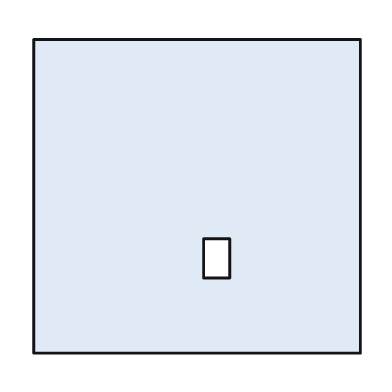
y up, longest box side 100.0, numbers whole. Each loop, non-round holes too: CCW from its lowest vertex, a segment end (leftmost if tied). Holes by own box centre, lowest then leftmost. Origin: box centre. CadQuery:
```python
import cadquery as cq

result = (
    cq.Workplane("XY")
    .moveTo(-50.0, -48.0)
    .lineTo(50.0, -48.0)
    .lineTo(50.0, 48.0)
    .lineTo(-50.0, 48.0)
    .close()
    .moveTo(2.0, -25.0)
    .lineTo(10.0, -25.0)
    .lineTo(10.0, -13.0)
    .lineTo(2.0, -13.0)
    .close()
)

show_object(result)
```